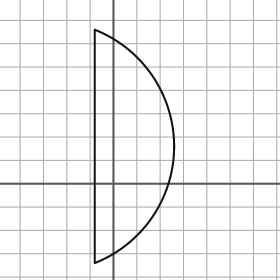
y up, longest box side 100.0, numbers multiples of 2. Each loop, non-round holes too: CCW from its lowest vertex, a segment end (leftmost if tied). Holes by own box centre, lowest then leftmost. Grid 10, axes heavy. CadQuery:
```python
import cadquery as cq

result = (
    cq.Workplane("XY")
    .moveTo(-8.0, -34.0)
    .threePointArc((26.0, 16.0), (-8.0, 66.0))
    .close()
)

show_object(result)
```